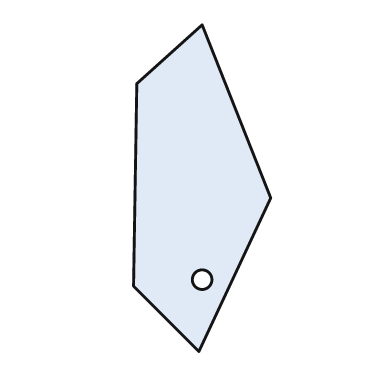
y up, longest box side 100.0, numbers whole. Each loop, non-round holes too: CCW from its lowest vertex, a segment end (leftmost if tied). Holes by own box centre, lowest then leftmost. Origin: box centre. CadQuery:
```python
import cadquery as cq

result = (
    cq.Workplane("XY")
    .moveTo(-1.0, -50.0)
    .lineTo(21.0, -3.0)
    .lineTo(0.0, 50.0)
    .lineTo(-20.0, 32.0)
    .lineTo(-21.0, -30.0)
    .close()
    .moveTo(0.0, -28.0)
    .circle(3.0)
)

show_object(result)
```